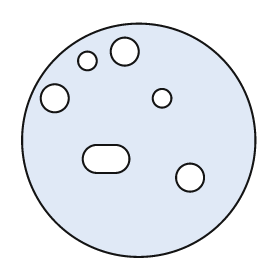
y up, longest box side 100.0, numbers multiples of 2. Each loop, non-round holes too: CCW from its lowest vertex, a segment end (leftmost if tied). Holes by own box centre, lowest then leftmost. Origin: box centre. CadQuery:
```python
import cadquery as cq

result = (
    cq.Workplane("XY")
    .moveTo(0.0, 0.0)
    .circle(50.0)
    .moveTo(22.0, -16.0)
    .circle(6.0)
    .moveTo(-18.0, -14.0)
    .lineTo(-10.0, -14.0)
    .threePointArc((-4.0, -8.0), (-10.0, -2.0))
    .lineTo(-18.0, -2.0)
    .threePointArc((-24.0, -8.0), (-18.0, -14.0))
    .close()
    .moveTo(-36.0, 18.0)
    .circle(6.0)
    .moveTo(10.0, 18.0)
    .circle(4.0)
    .moveTo(-22.0, 34.0)
    .circle(4.0)
    .moveTo(-6.0, 38.0)
    .circle(6.0)
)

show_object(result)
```